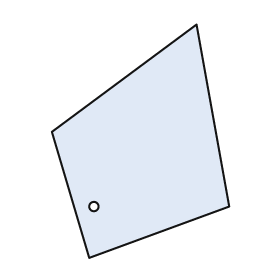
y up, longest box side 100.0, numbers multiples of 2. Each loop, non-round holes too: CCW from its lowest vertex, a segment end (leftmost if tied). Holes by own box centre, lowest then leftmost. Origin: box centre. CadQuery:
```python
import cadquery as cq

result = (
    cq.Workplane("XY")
    .moveTo(-22.0, -50.0)
    .lineTo(38.0, -28.0)
    .lineTo(24.0, 50.0)
    .lineTo(-38.0, 4.0)
    .close()
    .moveTo(-20.0, -28.0)
    .circle(2.0)
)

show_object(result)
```